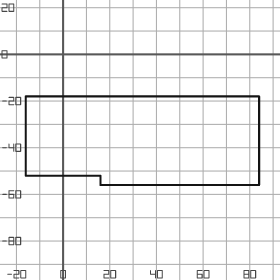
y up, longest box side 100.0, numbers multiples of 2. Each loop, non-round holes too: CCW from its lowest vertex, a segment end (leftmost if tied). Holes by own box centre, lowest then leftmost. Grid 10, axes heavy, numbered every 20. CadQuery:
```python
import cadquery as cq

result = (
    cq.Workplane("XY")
    .moveTo(16.0, -56.0)
    .lineTo(84.0, -56.0)
    .lineTo(84.0, -18.0)
    .lineTo(-16.0, -18.0)
    .lineTo(-16.0, -52.0)
    .lineTo(16.0, -52.0)
    .close()
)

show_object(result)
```